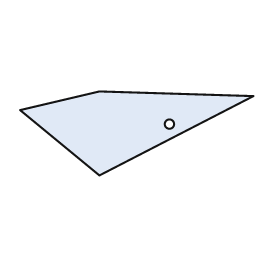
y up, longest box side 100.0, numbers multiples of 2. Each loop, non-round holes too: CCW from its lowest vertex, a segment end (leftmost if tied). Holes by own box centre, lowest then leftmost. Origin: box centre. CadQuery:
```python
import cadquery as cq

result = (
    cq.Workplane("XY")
    .moveTo(-16.0, -18.0)
    .lineTo(50.0, 16.0)
    .lineTo(-16.0, 18.0)
    .lineTo(-50.0, 10.0)
    .close()
    .moveTo(14.0, 4.0)
    .circle(2.0)
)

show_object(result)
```